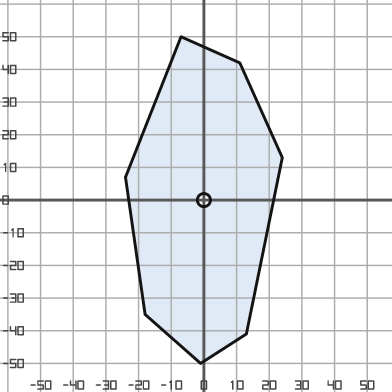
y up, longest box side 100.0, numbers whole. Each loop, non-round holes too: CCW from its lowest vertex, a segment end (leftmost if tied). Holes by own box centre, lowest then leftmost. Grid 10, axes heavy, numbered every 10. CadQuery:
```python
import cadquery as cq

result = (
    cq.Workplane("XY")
    .moveTo(-1.0, -50.0)
    .lineTo(13.0, -41.0)
    .lineTo(24.0, 13.0)
    .lineTo(11.0, 42.0)
    .lineTo(-7.0, 50.0)
    .lineTo(-24.0, 7.0)
    .lineTo(-18.0, -35.0)
    .close()
    .moveTo(0.0, 0.0)
    .circle(2.0)
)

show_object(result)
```